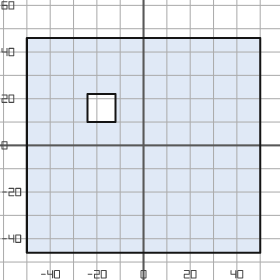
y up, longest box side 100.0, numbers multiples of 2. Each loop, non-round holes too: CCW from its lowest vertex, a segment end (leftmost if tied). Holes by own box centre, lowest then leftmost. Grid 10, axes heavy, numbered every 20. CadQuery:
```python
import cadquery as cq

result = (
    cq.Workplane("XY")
    .moveTo(-50.0, -46.0)
    .lineTo(50.0, -46.0)
    .lineTo(50.0, 46.0)
    .lineTo(-50.0, 46.0)
    .close()
    .moveTo(-24.0, 10.0)
    .lineTo(-12.0, 10.0)
    .lineTo(-12.0, 22.0)
    .lineTo(-24.0, 22.0)
    .close()
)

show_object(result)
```